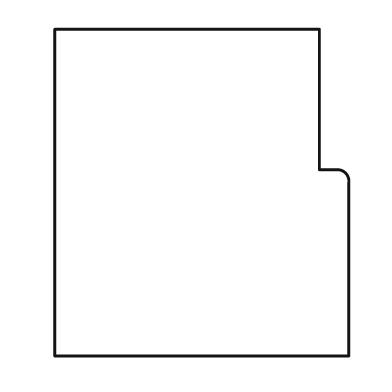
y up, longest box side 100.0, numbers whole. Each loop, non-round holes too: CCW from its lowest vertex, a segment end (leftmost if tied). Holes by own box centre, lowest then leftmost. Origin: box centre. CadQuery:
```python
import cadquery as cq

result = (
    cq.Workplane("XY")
    .moveTo(-45.0, -50.0)
    .lineTo(45.0, -50.0)
    .lineTo(45.0, 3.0)
    .threePointArc((44.0, 6.0), (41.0, 7.0))
    .lineTo(36.0, 7.0)
    .lineTo(36.0, 50.0)
    .lineTo(-45.0, 50.0)
    .close()
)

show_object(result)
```